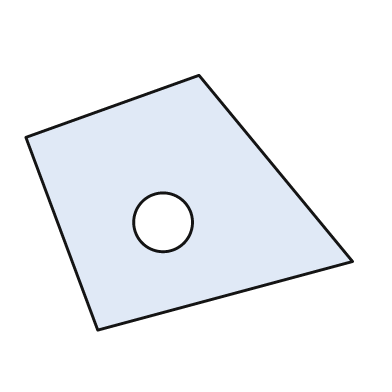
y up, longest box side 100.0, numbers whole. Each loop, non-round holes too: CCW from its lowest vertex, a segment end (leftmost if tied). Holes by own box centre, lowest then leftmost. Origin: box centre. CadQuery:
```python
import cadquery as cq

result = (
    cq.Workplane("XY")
    .moveTo(-28.0, -39.0)
    .lineTo(50.0, -18.0)
    .lineTo(3.0, 39.0)
    .lineTo(-50.0, 20.0)
    .close()
    .moveTo(-8.0, -6.0)
    .circle(9.0)
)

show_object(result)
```